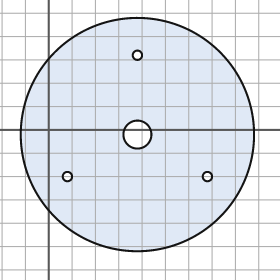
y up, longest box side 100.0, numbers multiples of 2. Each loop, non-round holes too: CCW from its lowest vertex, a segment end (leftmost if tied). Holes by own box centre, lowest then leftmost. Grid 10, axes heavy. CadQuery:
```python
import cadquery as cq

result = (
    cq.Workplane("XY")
    .moveTo(38.0, -2.0)
    .circle(50.0)
    .moveTo(8.0, -20.0)
    .circle(2.0)
    .moveTo(68.0, -20.0)
    .circle(2.0)
    .moveTo(38.0, -2.0)
    .circle(6.0)
    .moveTo(38.0, 32.0)
    .circle(2.0)
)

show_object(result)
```